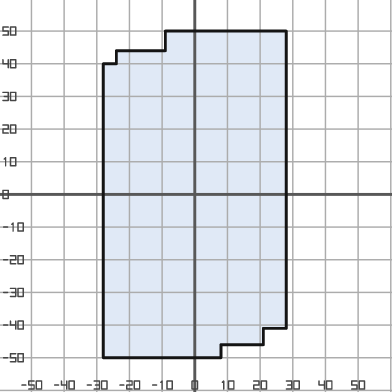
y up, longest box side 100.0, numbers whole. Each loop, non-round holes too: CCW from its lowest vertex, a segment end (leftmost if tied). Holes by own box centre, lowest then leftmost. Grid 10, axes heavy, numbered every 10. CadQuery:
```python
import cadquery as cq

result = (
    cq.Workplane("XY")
    .moveTo(-28.0, -50.0)
    .lineTo(8.0, -50.0)
    .lineTo(8.0, -46.0)
    .lineTo(21.0, -46.0)
    .lineTo(21.0, -41.0)
    .lineTo(28.0, -41.0)
    .lineTo(28.0, 50.0)
    .lineTo(-9.0, 50.0)
    .lineTo(-9.0, 44.0)
    .lineTo(-24.0, 44.0)
    .lineTo(-24.0, 40.0)
    .lineTo(-28.0, 40.0)
    .close()
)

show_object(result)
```